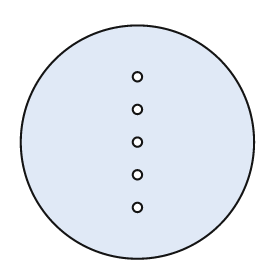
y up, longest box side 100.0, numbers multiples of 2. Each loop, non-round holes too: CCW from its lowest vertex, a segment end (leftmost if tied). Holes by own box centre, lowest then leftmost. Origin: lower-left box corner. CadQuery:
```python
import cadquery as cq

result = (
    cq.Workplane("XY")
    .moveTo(50.0, 50.0)
    .circle(50.0)
    .moveTo(50.0, 22.0)
    .circle(2.0)
    .moveTo(50.0, 36.0)
    .circle(2.0)
    .moveTo(50.0, 50.0)
    .circle(2.0)
    .moveTo(50.0, 64.0)
    .circle(2.0)
    .moveTo(50.0, 78.0)
    .circle(2.0)
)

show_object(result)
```